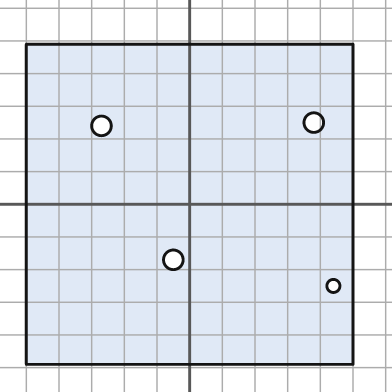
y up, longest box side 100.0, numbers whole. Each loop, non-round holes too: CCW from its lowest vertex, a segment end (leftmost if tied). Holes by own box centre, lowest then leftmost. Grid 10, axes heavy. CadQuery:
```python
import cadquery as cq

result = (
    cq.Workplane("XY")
    .moveTo(-50.0, -49.0)
    .lineTo(50.0, -49.0)
    .lineTo(50.0, 49.0)
    .lineTo(-50.0, 49.0)
    .close()
    .moveTo(44.0, -25.0)
    .circle(2.0)
    .moveTo(-5.0, -17.0)
    .circle(3.0)
    .moveTo(-27.0, 24.0)
    .circle(3.0)
    .moveTo(38.0, 25.0)
    .circle(3.0)
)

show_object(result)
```